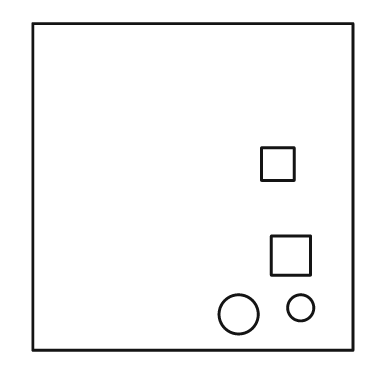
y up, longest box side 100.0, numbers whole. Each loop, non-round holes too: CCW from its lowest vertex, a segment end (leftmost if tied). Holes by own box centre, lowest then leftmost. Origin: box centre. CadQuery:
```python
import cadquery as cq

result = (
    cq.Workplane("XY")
    .moveTo(-49.0, -50.0)
    .lineTo(49.0, -50.0)
    .lineTo(49.0, 50.0)
    .lineTo(-49.0, 50.0)
    .close()
    .moveTo(14.0, -39.0)
    .circle(6.0)
    .moveTo(33.0, -37.0)
    .circle(4.0)
    .moveTo(24.0, -27.0)
    .lineTo(36.0, -27.0)
    .lineTo(36.0, -15.0)
    .lineTo(24.0, -15.0)
    .close()
    .moveTo(21.0, 2.0)
    .lineTo(31.0, 2.0)
    .lineTo(31.0, 12.0)
    .lineTo(21.0, 12.0)
    .close()
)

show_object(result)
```